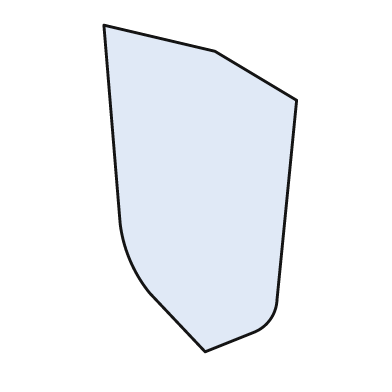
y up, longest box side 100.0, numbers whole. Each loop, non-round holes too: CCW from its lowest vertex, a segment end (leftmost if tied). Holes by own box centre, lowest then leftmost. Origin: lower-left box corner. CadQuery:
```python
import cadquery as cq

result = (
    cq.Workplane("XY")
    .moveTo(31.0, 0.0)
    .lineTo(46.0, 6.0)
    .threePointArc((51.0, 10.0), (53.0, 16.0))
    .lineTo(59.0, 77.0)
    .lineTo(34.0, 92.0)
    .lineTo(0.0, 100.0)
    .lineTo(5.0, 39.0)
    .threePointArc((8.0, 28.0), (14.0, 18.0))
    .close()
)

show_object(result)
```